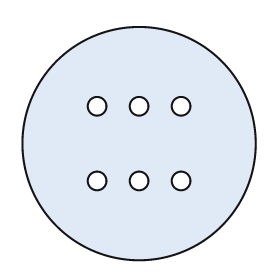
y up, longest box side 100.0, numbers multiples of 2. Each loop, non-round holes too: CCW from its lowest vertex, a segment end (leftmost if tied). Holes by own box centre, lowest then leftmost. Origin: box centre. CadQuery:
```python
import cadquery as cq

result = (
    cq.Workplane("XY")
    .moveTo(0.0, 0.0)
    .circle(50.0)
    .moveTo(-18.0, -16.0)
    .circle(4.0)
    .moveTo(0.0, -16.0)
    .circle(4.0)
    .moveTo(18.0, -16.0)
    .circle(4.0)
    .moveTo(-18.0, 16.0)
    .circle(4.0)
    .moveTo(0.0, 16.0)
    .circle(4.0)
    .moveTo(18.0, 16.0)
    .circle(4.0)
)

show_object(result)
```